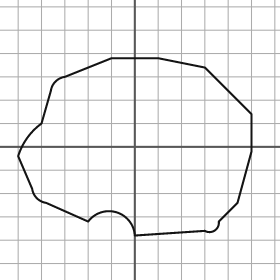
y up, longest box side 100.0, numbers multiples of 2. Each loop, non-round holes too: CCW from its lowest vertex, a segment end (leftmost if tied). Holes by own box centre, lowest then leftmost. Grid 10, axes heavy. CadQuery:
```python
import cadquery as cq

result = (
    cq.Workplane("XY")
    .moveTo(0.0, -38.0)
    .lineTo(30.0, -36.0)
    .threePointArc((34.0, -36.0), (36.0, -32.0))
    .lineTo(44.0, -24.0)
    .lineTo(50.0, -2.0)
    .lineTo(50.0, 14.0)
    .lineTo(30.0, 34.0)
    .lineTo(10.0, 38.0)
    .lineTo(-10.0, 38.0)
    .lineTo(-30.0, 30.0)
    .threePointArc((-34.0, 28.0), (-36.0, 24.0))
    .lineTo(-40.0, 10.0)
    .threePointArc((-46.0, 4.0), (-50.0, -4.0))
    .lineTo(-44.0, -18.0)
    .threePointArc((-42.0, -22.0), (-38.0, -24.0))
    .lineTo(-20.0, -32.0)
    .threePointArc((-8.0, -28.0), (0.0, -38.0))
    .close()
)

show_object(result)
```